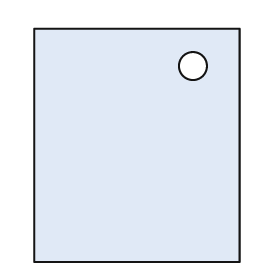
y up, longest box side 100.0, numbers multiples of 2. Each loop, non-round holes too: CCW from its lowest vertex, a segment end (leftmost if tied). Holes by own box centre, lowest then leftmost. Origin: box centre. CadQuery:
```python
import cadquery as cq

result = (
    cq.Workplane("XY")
    .moveTo(-44.0, -50.0)
    .lineTo(44.0, -50.0)
    .lineTo(44.0, 50.0)
    .lineTo(-44.0, 50.0)
    .close()
    .moveTo(24.0, 34.0)
    .circle(6.0)
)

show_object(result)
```